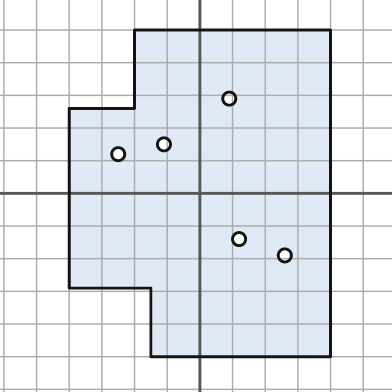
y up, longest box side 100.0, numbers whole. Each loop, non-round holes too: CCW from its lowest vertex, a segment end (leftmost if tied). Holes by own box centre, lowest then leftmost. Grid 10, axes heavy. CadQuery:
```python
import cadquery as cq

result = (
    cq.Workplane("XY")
    .moveTo(-15.0, -50.0)
    .lineTo(40.0, -50.0)
    .lineTo(40.0, 50.0)
    .lineTo(-20.0, 50.0)
    .lineTo(-20.0, 26.0)
    .lineTo(-40.0, 26.0)
    .lineTo(-40.0, -29.0)
    .lineTo(-15.0, -29.0)
    .close()
    .moveTo(26.0, -19.0)
    .circle(2.0)
    .moveTo(12.0, -14.0)
    .circle(2.0)
    .moveTo(-25.0, 12.0)
    .circle(2.0)
    .moveTo(-11.0, 15.0)
    .circle(2.0)
    .moveTo(9.0, 29.0)
    .circle(2.0)
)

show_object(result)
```